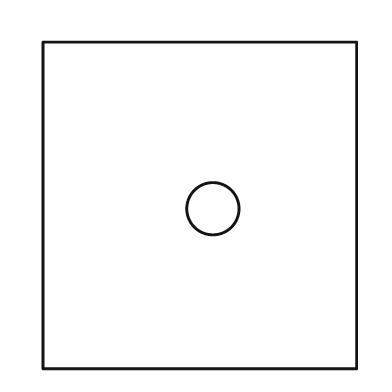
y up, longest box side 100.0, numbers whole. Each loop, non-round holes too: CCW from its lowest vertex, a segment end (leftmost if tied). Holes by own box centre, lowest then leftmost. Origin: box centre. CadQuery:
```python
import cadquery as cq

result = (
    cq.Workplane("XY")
    .moveTo(-48.0, -50.0)
    .lineTo(48.0, -50.0)
    .lineTo(48.0, 50.0)
    .lineTo(-48.0, 50.0)
    .close()
    .moveTo(4.0, -1.0)
    .circle(8.0)
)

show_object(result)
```